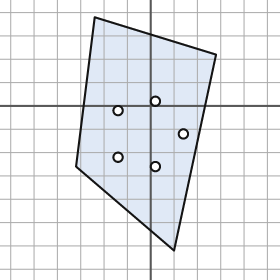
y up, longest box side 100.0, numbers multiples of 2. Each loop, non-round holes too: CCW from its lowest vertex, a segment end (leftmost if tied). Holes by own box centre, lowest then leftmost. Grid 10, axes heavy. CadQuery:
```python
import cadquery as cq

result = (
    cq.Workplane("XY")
    .moveTo(10.0, -62.0)
    .lineTo(28.0, 22.0)
    .lineTo(-24.0, 38.0)
    .lineTo(-32.0, -26.0)
    .close()
    .moveTo(2.0, -26.0)
    .circle(2.0)
    .moveTo(-14.0, -22.0)
    .circle(2.0)
    .moveTo(14.0, -12.0)
    .circle(2.0)
    .moveTo(-14.0, -2.0)
    .circle(2.0)
    .moveTo(2.0, 2.0)
    .circle(2.0)
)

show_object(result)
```